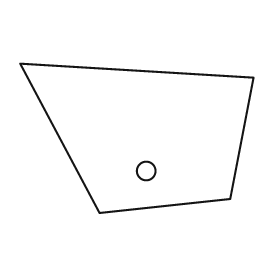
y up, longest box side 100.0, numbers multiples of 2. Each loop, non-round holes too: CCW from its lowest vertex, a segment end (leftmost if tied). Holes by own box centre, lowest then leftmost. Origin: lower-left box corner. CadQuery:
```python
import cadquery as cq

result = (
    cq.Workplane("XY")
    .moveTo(34.0, 0.0)
    .lineTo(90.0, 6.0)
    .lineTo(100.0, 58.0)
    .lineTo(0.0, 64.0)
    .close()
    .moveTo(54.0, 18.0)
    .circle(4.0)
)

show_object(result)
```